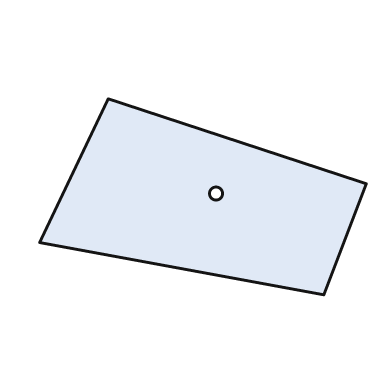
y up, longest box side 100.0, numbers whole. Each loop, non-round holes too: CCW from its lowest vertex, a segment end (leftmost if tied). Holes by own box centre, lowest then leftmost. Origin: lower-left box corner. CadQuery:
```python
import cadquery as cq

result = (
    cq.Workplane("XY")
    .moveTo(87.0, 0.0)
    .lineTo(100.0, 34.0)
    .lineTo(21.0, 60.0)
    .lineTo(0.0, 16.0)
    .close()
    .moveTo(54.0, 31.0)
    .circle(2.0)
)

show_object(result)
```